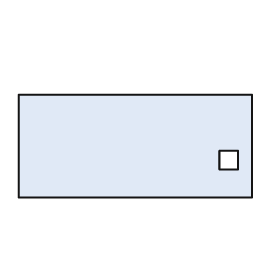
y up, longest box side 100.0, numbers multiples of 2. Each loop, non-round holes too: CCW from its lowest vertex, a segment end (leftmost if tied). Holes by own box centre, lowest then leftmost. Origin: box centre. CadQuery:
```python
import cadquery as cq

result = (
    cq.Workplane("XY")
    .moveTo(-50.0, -22.0)
    .lineTo(50.0, -22.0)
    .lineTo(50.0, 22.0)
    .lineTo(-50.0, 22.0)
    .close()
    .moveTo(36.0, -10.0)
    .lineTo(44.0, -10.0)
    .lineTo(44.0, -2.0)
    .lineTo(36.0, -2.0)
    .close()
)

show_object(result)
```